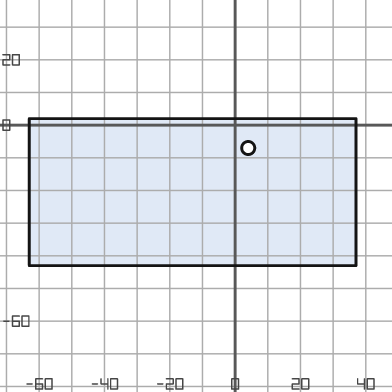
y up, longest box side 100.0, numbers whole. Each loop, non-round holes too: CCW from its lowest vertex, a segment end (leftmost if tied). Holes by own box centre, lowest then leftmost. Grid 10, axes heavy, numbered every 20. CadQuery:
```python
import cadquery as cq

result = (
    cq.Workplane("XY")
    .moveTo(-63.0, -43.0)
    .lineTo(37.0, -43.0)
    .lineTo(37.0, 2.0)
    .lineTo(-63.0, 2.0)
    .close()
    .moveTo(4.0, -7.0)
    .circle(2.0)
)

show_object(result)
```